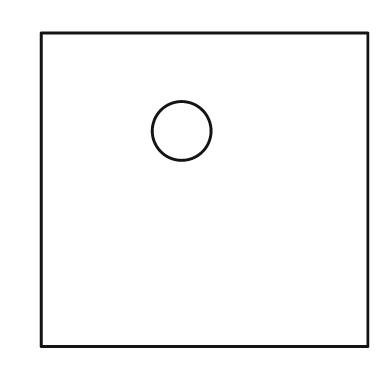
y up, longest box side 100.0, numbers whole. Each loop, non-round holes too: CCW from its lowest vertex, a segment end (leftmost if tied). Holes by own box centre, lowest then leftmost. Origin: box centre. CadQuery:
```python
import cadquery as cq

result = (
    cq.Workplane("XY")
    .moveTo(-50.0, -48.0)
    .lineTo(50.0, -48.0)
    .lineTo(50.0, 48.0)
    .lineTo(-50.0, 48.0)
    .close()
    .moveTo(-7.0, 18.0)
    .circle(9.0)
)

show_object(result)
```